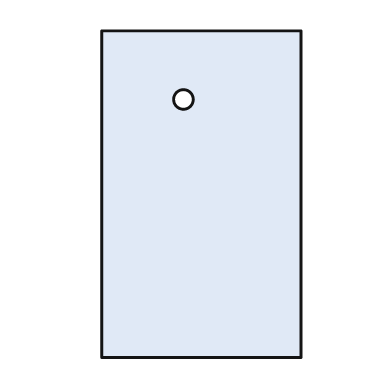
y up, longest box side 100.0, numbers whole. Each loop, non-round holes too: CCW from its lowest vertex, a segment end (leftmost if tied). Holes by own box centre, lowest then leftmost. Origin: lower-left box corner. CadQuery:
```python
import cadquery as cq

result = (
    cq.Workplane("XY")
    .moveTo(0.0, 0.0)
    .lineTo(61.0, 0.0)
    .lineTo(61.0, 100.0)
    .lineTo(0.0, 100.0)
    .close()
    .moveTo(25.0, 79.0)
    .circle(3.0)
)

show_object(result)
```